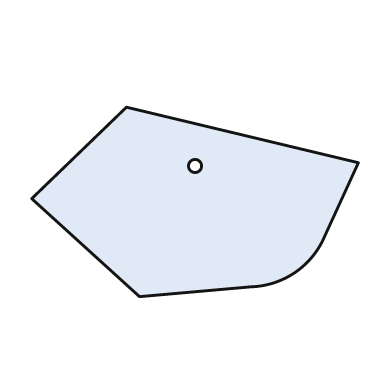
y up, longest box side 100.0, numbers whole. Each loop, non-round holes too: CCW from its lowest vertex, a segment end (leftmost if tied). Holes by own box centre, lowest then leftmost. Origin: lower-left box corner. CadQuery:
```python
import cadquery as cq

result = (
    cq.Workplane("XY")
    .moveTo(33.0, 0.0)
    .lineTo(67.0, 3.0)
    .threePointArc((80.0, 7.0), (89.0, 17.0))
    .lineTo(100.0, 41.0)
    .lineTo(29.0, 58.0)
    .lineTo(0.0, 30.0)
    .close()
    .moveTo(50.0, 40.0)
    .circle(2.0)
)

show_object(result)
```